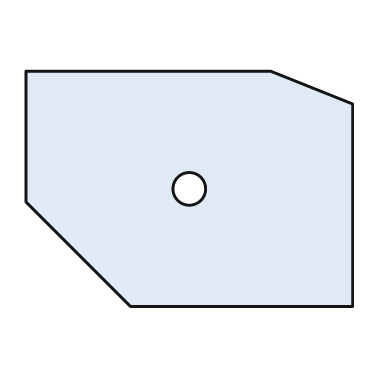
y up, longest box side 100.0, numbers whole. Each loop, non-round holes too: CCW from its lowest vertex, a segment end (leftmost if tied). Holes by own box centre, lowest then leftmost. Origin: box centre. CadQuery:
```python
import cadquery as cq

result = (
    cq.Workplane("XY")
    .moveTo(-18.0, -36.0)
    .lineTo(50.0, -36.0)
    .lineTo(50.0, 26.0)
    .lineTo(25.0, 36.0)
    .lineTo(-50.0, 36.0)
    .lineTo(-50.0, -4.0)
    .close()
    .moveTo(0.0, 0.0)
    .circle(5.0)
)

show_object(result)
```